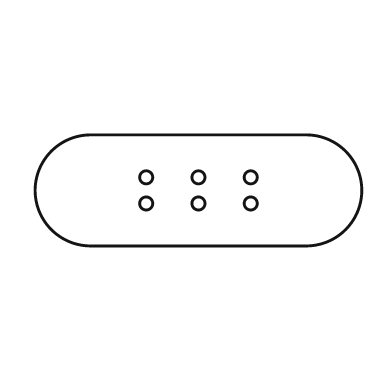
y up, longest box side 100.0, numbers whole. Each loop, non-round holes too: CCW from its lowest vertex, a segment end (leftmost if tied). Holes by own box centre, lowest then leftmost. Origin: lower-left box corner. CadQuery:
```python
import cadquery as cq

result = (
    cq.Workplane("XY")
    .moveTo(17.0, 0.0)
    .lineTo(83.0, 0.0)
    .threePointArc((100.0, 17.0), (83.0, 34.0))
    .lineTo(17.0, 34.0)
    .threePointArc((0.0, 17.0), (17.0, 0.0))
    .close()
    .moveTo(34.0, 13.0)
    .circle(2.0)
    .moveTo(50.0, 13.0)
    .circle(2.0)
    .moveTo(66.0, 13.0)
    .circle(2.0)
    .moveTo(34.0, 21.0)
    .circle(2.0)
    .moveTo(50.0, 21.0)
    .circle(2.0)
    .moveTo(66.0, 21.0)
    .circle(2.0)
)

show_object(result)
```